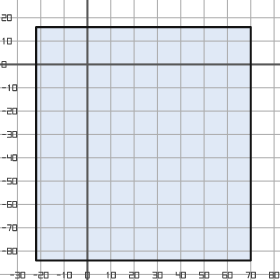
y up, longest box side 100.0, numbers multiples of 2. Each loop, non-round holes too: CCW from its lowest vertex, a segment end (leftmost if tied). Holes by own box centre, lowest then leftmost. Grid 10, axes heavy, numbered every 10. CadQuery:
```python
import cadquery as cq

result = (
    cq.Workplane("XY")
    .moveTo(-22.0, -84.0)
    .lineTo(70.0, -84.0)
    .lineTo(70.0, 16.0)
    .lineTo(-22.0, 16.0)
    .close()
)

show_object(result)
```